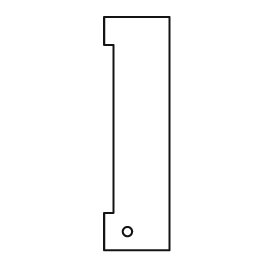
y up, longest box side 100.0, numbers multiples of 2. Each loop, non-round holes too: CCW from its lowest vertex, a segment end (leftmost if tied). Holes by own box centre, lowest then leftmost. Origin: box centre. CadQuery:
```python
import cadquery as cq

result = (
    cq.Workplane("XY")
    .moveTo(-14.0, -50.0)
    .lineTo(14.0, -50.0)
    .lineTo(14.0, 50.0)
    .lineTo(-14.0, 50.0)
    .lineTo(-14.0, 38.0)
    .lineTo(-10.0, 38.0)
    .lineTo(-10.0, -34.0)
    .lineTo(-14.0, -34.0)
    .close()
    .moveTo(-4.0, -42.0)
    .circle(2.0)
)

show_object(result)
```